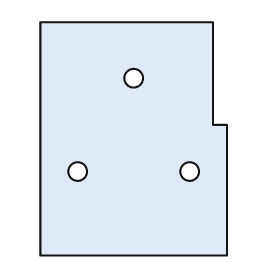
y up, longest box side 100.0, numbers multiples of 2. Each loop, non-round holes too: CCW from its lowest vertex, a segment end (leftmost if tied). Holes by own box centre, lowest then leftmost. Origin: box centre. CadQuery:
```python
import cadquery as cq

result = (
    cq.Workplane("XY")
    .moveTo(-40.0, -50.0)
    .lineTo(40.0, -50.0)
    .lineTo(40.0, 6.0)
    .lineTo(34.0, 6.0)
    .lineTo(34.0, 50.0)
    .lineTo(-40.0, 50.0)
    .close()
    .moveTo(-24.0, -14.0)
    .circle(4.0)
    .moveTo(24.0, -14.0)
    .circle(4.0)
    .moveTo(0.0, 26.0)
    .circle(4.0)
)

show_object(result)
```